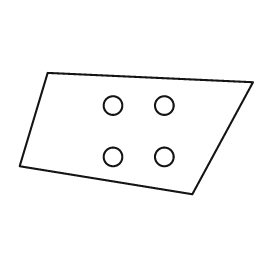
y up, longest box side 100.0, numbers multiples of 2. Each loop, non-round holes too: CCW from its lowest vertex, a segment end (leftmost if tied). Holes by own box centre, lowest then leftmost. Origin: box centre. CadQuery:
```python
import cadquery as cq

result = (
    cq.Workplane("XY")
    .moveTo(24.0, -26.0)
    .lineTo(50.0, 22.0)
    .lineTo(-38.0, 26.0)
    .lineTo(-50.0, -14.0)
    .close()
    .moveTo(-10.0, -10.0)
    .circle(4.0)
    .moveTo(12.0, -10.0)
    .circle(4.0)
    .moveTo(-10.0, 12.0)
    .circle(4.0)
    .moveTo(12.0, 12.0)
    .circle(4.0)
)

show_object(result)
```